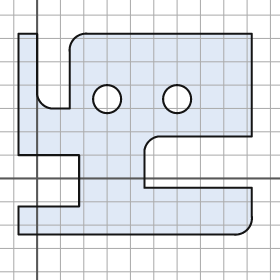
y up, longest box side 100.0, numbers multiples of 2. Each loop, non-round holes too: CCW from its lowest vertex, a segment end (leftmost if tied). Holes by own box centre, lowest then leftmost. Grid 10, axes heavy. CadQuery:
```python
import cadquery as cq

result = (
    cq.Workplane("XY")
    .moveTo(-8.0, -24.0)
    .lineTo(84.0, -24.0)
    .threePointArc((90.0, -22.0), (92.0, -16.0))
    .lineTo(92.0, -4.0)
    .lineTo(46.0, -4.0)
    .lineTo(46.0, 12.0)
    .threePointArc((48.0, 16.0), (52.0, 18.0))
    .lineTo(92.0, 18.0)
    .lineTo(92.0, 62.0)
    .lineTo(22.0, 62.0)
    .threePointArc((16.0, 60.0), (14.0, 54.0))
    .lineTo(14.0, 30.0)
    .lineTo(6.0, 30.0)
    .threePointArc((2.0, 32.0), (0.0, 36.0))
    .lineTo(0.0, 62.0)
    .lineTo(-8.0, 62.0)
    .lineTo(-8.0, 10.0)
    .lineTo(18.0, 10.0)
    .lineTo(18.0, -12.0)
    .lineTo(-8.0, -12.0)
    .close()
    .moveTo(30.0, 34.0)
    .circle(6.0)
    .moveTo(60.0, 34.0)
    .circle(6.0)
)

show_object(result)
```